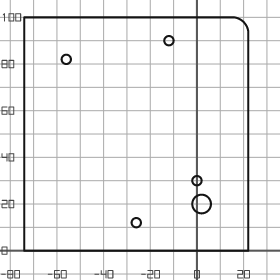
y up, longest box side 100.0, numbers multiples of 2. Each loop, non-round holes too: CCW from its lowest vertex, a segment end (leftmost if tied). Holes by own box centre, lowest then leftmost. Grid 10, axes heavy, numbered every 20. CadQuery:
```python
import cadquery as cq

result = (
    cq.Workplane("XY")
    .moveTo(-74.0, 0.0)
    .lineTo(22.0, 0.0)
    .lineTo(22.0, 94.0)
    .threePointArc((20.0, 98.0), (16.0, 100.0))
    .lineTo(-74.0, 100.0)
    .close()
    .moveTo(-26.0, 12.0)
    .circle(2.0)
    .moveTo(2.0, 20.0)
    .circle(4.0)
    .moveTo(0.0, 30.0)
    .circle(2.0)
    .moveTo(-56.0, 82.0)
    .circle(2.0)
    .moveTo(-12.0, 90.0)
    .circle(2.0)
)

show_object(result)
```